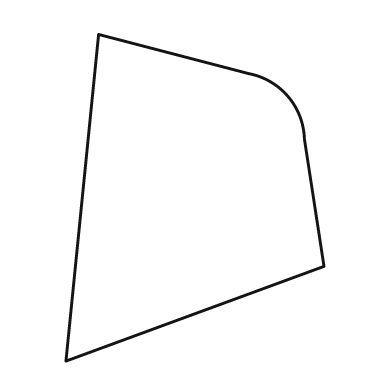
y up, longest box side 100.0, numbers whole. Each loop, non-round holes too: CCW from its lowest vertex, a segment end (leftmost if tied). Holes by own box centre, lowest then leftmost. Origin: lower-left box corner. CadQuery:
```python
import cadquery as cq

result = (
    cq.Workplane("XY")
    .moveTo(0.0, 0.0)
    .lineTo(79.0, 29.0)
    .lineTo(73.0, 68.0)
    .threePointArc((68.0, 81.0), (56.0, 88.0))
    .lineTo(10.0, 100.0)
    .close()
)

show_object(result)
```